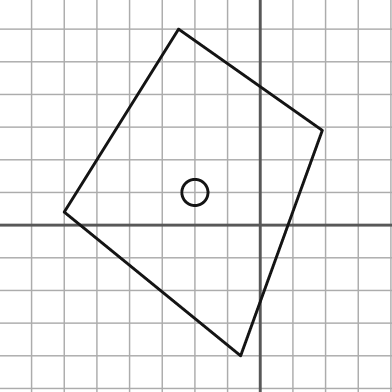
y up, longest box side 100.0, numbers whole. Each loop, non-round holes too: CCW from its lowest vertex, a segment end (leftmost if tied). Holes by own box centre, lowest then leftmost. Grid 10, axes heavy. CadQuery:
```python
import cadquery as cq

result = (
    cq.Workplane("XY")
    .moveTo(-6.0, -40.0)
    .lineTo(19.0, 29.0)
    .lineTo(-25.0, 60.0)
    .lineTo(-60.0, 4.0)
    .close()
    .moveTo(-20.0, 10.0)
    .circle(4.0)
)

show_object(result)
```